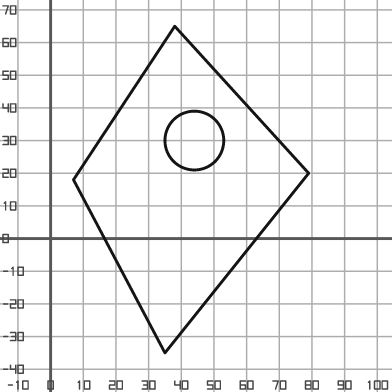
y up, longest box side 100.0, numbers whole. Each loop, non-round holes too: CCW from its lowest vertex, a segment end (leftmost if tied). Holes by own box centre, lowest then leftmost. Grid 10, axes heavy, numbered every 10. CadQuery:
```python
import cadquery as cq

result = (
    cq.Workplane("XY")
    .moveTo(35.0, -35.0)
    .lineTo(79.0, 20.0)
    .lineTo(38.0, 65.0)
    .lineTo(7.0, 18.0)
    .close()
    .moveTo(44.0, 30.0)
    .circle(9.0)
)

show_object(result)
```